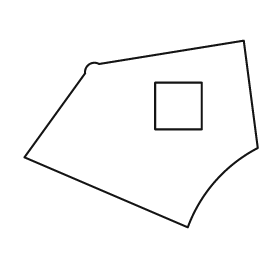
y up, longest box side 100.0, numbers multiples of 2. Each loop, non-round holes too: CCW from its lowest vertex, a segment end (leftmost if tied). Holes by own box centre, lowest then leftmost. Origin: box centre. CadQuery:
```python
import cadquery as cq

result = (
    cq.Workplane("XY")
    .moveTo(20.0, -40.0)
    .threePointArc((32.0, -20.0), (50.0, -6.0))
    .lineTo(44.0, 40.0)
    .lineTo(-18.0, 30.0)
    .threePointArc((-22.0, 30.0), (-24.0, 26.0))
    .lineTo(-50.0, -10.0)
    .close()
    .moveTo(6.0, 2.0)
    .lineTo(26.0, 2.0)
    .lineTo(26.0, 22.0)
    .lineTo(6.0, 22.0)
    .close()
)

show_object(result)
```